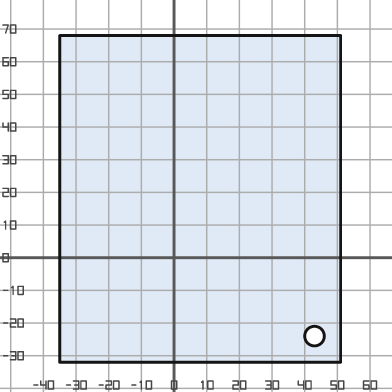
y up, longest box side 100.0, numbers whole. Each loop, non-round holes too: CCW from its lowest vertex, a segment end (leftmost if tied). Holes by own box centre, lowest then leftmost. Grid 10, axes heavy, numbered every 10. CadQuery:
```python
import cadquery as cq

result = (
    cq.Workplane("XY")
    .moveTo(-35.0, -32.0)
    .lineTo(51.0, -32.0)
    .lineTo(51.0, 68.0)
    .lineTo(-35.0, 68.0)
    .close()
    .moveTo(43.0, -24.0)
    .circle(3.0)
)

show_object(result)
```